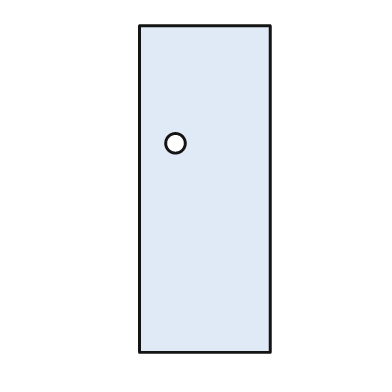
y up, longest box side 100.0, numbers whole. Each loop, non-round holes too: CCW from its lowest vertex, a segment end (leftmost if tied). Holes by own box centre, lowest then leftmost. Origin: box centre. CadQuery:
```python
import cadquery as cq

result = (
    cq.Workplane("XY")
    .moveTo(-20.0, -50.0)
    .lineTo(20.0, -50.0)
    .lineTo(20.0, 50.0)
    .lineTo(-20.0, 50.0)
    .close()
    .moveTo(-9.0, 14.0)
    .circle(3.0)
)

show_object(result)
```